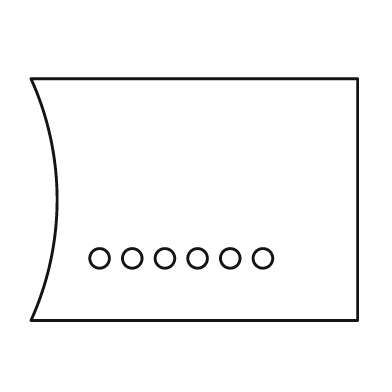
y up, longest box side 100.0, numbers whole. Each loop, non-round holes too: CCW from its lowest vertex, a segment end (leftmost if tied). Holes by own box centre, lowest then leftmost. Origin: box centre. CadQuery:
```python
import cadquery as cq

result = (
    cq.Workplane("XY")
    .moveTo(-50.0, -37.0)
    .lineTo(50.0, -37.0)
    .lineTo(50.0, 37.0)
    .lineTo(-50.0, 37.0)
    .threePointArc((-42.0, 0.0), (-50.0, -37.0))
    .close()
    .moveTo(-29.0, -18.0)
    .circle(3.0)
    .moveTo(-19.0, -18.0)
    .circle(3.0)
    .moveTo(-9.0, -18.0)
    .circle(3.0)
    .moveTo(1.0, -18.0)
    .circle(3.0)
    .moveTo(11.0, -18.0)
    .circle(3.0)
    .moveTo(21.0, -18.0)
    .circle(3.0)
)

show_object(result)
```